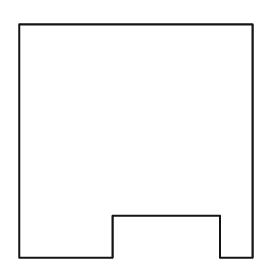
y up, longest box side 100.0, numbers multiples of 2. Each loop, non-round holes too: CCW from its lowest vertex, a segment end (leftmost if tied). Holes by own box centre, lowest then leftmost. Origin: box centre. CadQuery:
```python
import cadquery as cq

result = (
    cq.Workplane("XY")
    .moveTo(-50.0, -50.0)
    .lineTo(-10.0, -50.0)
    .lineTo(-10.0, -32.0)
    .lineTo(36.0, -32.0)
    .lineTo(36.0, -50.0)
    .lineTo(50.0, -50.0)
    .lineTo(50.0, 50.0)
    .lineTo(-50.0, 50.0)
    .close()
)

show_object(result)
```